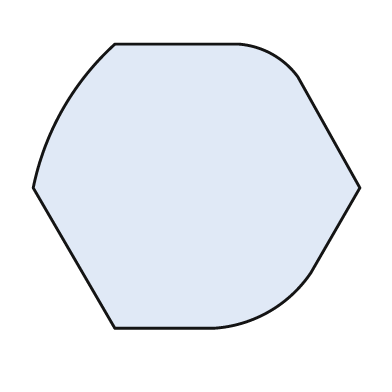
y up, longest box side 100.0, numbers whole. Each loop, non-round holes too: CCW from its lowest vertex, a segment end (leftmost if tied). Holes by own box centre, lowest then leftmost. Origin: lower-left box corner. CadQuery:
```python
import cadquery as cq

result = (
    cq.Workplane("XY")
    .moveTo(25.0, 0.0)
    .lineTo(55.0, 0.0)
    .threePointArc((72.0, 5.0), (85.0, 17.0))
    .lineTo(100.0, 43.0)
    .lineTo(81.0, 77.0)
    .threePointArc((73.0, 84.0), (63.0, 87.0))
    .lineTo(25.0, 87.0)
    .threePointArc((9.0, 67.0), (0.0, 43.0))
    .close()
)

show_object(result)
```